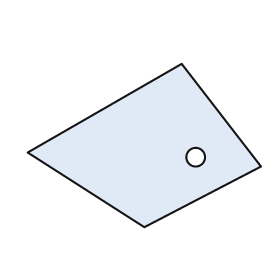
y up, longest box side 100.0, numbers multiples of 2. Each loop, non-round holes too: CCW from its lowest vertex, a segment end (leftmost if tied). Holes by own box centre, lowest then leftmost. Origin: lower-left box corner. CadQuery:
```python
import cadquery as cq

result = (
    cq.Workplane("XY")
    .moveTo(50.0, 0.0)
    .lineTo(100.0, 26.0)
    .lineTo(66.0, 70.0)
    .lineTo(0.0, 32.0)
    .close()
    .moveTo(72.0, 30.0)
    .circle(4.0)
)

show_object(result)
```